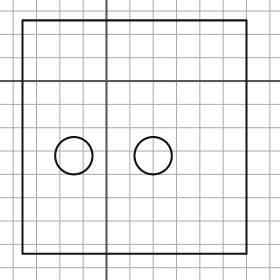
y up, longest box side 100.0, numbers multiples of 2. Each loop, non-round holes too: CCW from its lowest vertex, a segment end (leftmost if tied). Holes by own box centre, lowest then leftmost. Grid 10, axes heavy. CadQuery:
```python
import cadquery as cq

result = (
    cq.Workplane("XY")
    .moveTo(-36.0, -74.0)
    .lineTo(60.0, -74.0)
    .lineTo(60.0, 26.0)
    .lineTo(-36.0, 26.0)
    .close()
    .moveTo(-14.0, -32.0)
    .circle(8.0)
    .moveTo(20.0, -32.0)
    .circle(8.0)
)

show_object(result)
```